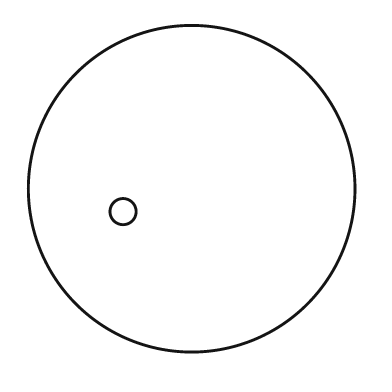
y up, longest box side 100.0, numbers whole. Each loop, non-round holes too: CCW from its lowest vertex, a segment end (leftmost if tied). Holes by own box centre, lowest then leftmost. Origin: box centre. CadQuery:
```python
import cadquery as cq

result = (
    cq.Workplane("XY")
    .moveTo(0.0, 0.0)
    .circle(50.0)
    .moveTo(-21.0, -7.0)
    .circle(4.0)
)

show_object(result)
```